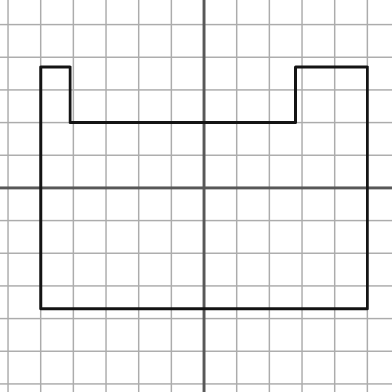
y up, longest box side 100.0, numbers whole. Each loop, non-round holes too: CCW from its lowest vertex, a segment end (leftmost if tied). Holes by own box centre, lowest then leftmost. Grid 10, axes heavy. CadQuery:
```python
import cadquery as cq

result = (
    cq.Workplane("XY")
    .moveTo(-50.0, -37.0)
    .lineTo(50.0, -37.0)
    .lineTo(50.0, 37.0)
    .lineTo(28.0, 37.0)
    .lineTo(28.0, 20.0)
    .lineTo(-41.0, 20.0)
    .lineTo(-41.0, 37.0)
    .lineTo(-50.0, 37.0)
    .close()
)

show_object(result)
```